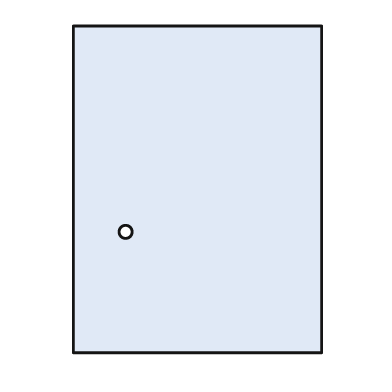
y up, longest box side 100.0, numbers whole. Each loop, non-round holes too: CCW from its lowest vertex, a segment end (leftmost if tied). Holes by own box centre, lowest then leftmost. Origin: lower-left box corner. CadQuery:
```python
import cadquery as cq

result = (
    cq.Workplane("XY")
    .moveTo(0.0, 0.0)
    .lineTo(76.0, 0.0)
    .lineTo(76.0, 100.0)
    .lineTo(0.0, 100.0)
    .close()
    .moveTo(16.0, 37.0)
    .circle(2.0)
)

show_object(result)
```